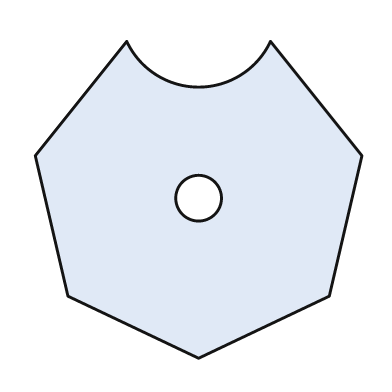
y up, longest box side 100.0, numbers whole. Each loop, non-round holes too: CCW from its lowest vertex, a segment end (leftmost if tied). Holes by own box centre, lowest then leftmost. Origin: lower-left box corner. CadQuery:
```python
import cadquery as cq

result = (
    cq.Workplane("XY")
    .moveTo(50.0, 0.0)
    .lineTo(90.0, 19.0)
    .lineTo(100.0, 62.0)
    .lineTo(72.0, 97.0)
    .threePointArc((50.0, 83.0), (28.0, 97.0))
    .lineTo(0.0, 62.0)
    .lineTo(10.0, 19.0)
    .close()
    .moveTo(50.0, 49.0)
    .circle(7.0)
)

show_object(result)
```